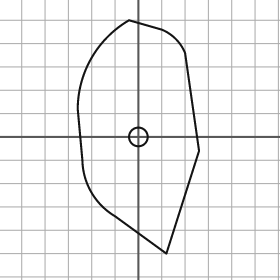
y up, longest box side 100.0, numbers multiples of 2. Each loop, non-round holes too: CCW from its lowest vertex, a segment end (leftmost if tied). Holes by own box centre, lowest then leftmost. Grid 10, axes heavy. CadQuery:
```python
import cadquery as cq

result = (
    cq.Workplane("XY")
    .moveTo(12.0, -50.0)
    .lineTo(26.0, -6.0)
    .lineTo(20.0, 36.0)
    .threePointArc((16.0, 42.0), (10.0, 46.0))
    .lineTo(-4.0, 50.0)
    .threePointArc((-20.0, 34.0), (-26.0, 12.0))
    .lineTo(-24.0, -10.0)
    .threePointArc((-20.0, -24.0), (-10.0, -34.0))
    .close()
    .moveTo(0.0, 0.0)
    .circle(4.0)
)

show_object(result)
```